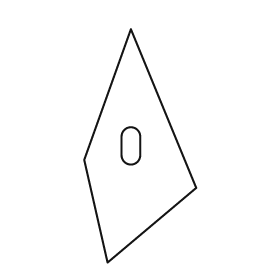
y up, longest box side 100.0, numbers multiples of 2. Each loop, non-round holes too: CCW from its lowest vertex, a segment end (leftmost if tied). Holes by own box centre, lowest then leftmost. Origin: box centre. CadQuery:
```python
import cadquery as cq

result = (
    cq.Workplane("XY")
    .moveTo(-14.0, -50.0)
    .lineTo(24.0, -18.0)
    .lineTo(-4.0, 50.0)
    .lineTo(-24.0, -6.0)
    .close()
    .moveTo(-8.0, -4.0)
    .threePointArc((-4.0, -8.0), (0.0, -4.0))
    .lineTo(0.0, 4.0)
    .threePointArc((-4.0, 8.0), (-8.0, 4.0))
    .close()
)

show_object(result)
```